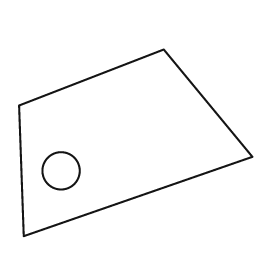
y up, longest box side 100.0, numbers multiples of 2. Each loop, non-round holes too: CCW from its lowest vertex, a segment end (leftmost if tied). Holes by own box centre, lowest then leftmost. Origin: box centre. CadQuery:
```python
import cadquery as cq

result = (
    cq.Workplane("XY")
    .moveTo(-48.0, -40.0)
    .lineTo(50.0, -6.0)
    .lineTo(12.0, 40.0)
    .lineTo(-50.0, 16.0)
    .close()
    .moveTo(-32.0, -12.0)
    .circle(8.0)
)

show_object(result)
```